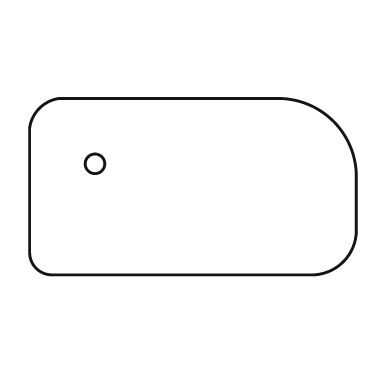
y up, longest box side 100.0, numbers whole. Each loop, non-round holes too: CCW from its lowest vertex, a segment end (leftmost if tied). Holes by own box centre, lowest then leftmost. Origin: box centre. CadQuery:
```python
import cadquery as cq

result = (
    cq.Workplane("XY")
    .moveTo(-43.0, -27.0)
    .lineTo(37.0, -27.0)
    .threePointArc((46.0, -23.0), (50.0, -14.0))
    .lineTo(50.0, 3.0)
    .threePointArc((43.0, 20.0), (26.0, 27.0))
    .lineTo(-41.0, 27.0)
    .threePointArc((-47.0, 24.0), (-50.0, 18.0))
    .lineTo(-50.0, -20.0)
    .threePointArc((-48.0, -25.0), (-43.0, -27.0))
    .close()
    .moveTo(-30.0, 7.0)
    .circle(3.0)
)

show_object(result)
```